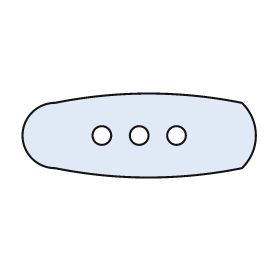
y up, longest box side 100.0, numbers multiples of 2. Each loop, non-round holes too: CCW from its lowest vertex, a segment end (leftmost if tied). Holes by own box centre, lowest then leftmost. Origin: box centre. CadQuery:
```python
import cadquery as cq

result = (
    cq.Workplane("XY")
    .moveTo(-36.0, -14.0)
    .threePointArc((4.0, -18.0), (44.0, -14.0))
    .threePointArc((50.0, 0.0), (44.0, 14.0))
    .threePointArc((4.0, 18.0), (-36.0, 14.0))
    .threePointArc((-50.0, 0.0), (-36.0, -14.0))
    .close()
    .moveTo(-16.0, 0.0)
    .circle(4.0)
    .moveTo(0.0, 0.0)
    .circle(4.0)
    .moveTo(16.0, 0.0)
    .circle(4.0)
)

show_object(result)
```